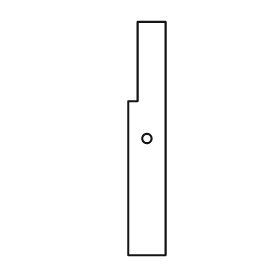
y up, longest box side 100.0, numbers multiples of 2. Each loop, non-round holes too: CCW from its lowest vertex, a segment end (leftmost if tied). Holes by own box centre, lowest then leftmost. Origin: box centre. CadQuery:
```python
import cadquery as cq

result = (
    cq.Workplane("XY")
    .moveTo(-8.0, -50.0)
    .lineTo(8.0, -50.0)
    .lineTo(8.0, 50.0)
    .lineTo(-4.0, 50.0)
    .lineTo(-4.0, 16.0)
    .lineTo(-8.0, 16.0)
    .close()
    .moveTo(0.0, 0.0)
    .circle(2.0)
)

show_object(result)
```